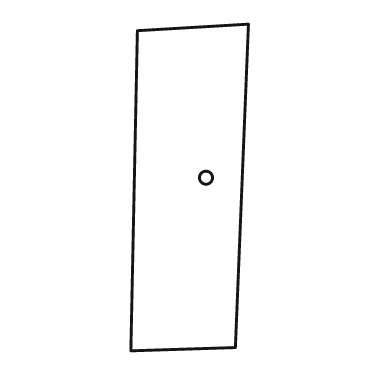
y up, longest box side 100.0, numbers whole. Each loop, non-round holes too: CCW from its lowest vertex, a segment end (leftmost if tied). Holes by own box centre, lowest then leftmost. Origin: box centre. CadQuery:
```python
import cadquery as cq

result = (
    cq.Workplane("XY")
    .moveTo(-18.0, -50.0)
    .lineTo(14.0, -49.0)
    .lineTo(18.0, 50.0)
    .lineTo(-16.0, 48.0)
    .close()
    .moveTo(5.0, 3.0)
    .circle(2.0)
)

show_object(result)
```